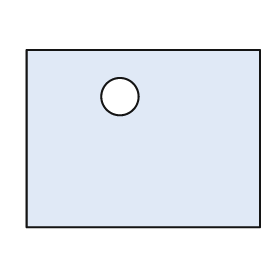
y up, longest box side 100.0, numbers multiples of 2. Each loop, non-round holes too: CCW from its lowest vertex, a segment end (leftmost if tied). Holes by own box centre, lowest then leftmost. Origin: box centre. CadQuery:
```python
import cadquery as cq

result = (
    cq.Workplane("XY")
    .moveTo(-50.0, -38.0)
    .lineTo(50.0, -38.0)
    .lineTo(50.0, 38.0)
    .lineTo(-50.0, 38.0)
    .close()
    .moveTo(-10.0, 18.0)
    .circle(8.0)
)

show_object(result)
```